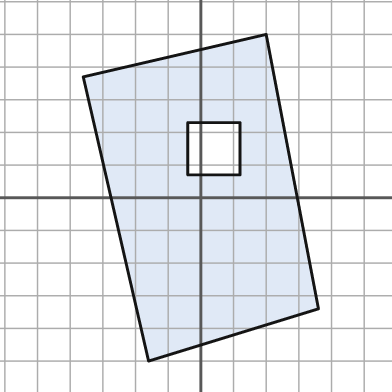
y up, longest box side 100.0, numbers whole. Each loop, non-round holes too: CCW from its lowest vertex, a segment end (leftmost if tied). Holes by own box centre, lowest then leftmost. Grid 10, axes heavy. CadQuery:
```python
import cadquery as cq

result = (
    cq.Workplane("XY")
    .moveTo(-16.0, -50.0)
    .lineTo(36.0, -34.0)
    .lineTo(20.0, 50.0)
    .lineTo(-36.0, 37.0)
    .close()
    .moveTo(-4.0, 7.0)
    .lineTo(12.0, 7.0)
    .lineTo(12.0, 23.0)
    .lineTo(-4.0, 23.0)
    .close()
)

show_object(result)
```